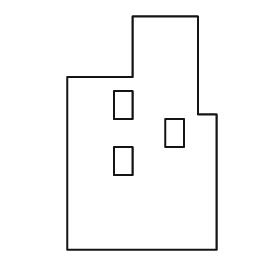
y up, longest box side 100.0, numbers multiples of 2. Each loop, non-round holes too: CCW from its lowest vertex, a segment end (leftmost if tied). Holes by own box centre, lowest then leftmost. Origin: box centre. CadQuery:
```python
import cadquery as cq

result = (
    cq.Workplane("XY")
    .moveTo(-32.0, -50.0)
    .lineTo(32.0, -50.0)
    .lineTo(32.0, 8.0)
    .lineTo(24.0, 8.0)
    .lineTo(24.0, 50.0)
    .lineTo(-4.0, 50.0)
    .lineTo(-4.0, 24.0)
    .lineTo(-32.0, 24.0)
    .close()
    .moveTo(-12.0, -18.0)
    .lineTo(-4.0, -18.0)
    .lineTo(-4.0, -6.0)
    .lineTo(-12.0, -6.0)
    .close()
    .moveTo(10.0, -6.0)
    .lineTo(18.0, -6.0)
    .lineTo(18.0, 6.0)
    .lineTo(10.0, 6.0)
    .close()
    .moveTo(-12.0, 6.0)
    .lineTo(-4.0, 6.0)
    .lineTo(-4.0, 18.0)
    .lineTo(-12.0, 18.0)
    .close()
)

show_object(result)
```